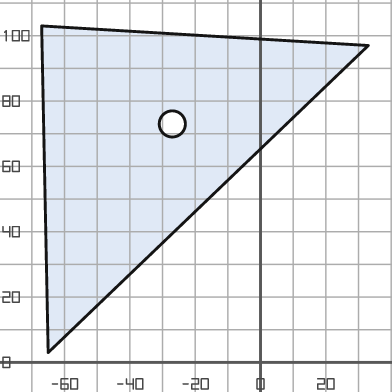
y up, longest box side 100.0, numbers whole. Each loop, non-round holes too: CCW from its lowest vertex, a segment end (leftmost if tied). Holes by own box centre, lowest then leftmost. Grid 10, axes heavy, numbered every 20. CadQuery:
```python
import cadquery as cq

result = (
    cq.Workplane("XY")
    .moveTo(-65.0, 3.0)
    .lineTo(33.0, 97.0)
    .lineTo(-67.0, 103.0)
    .close()
    .moveTo(-27.0, 73.0)
    .circle(4.0)
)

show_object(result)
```